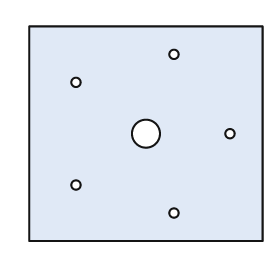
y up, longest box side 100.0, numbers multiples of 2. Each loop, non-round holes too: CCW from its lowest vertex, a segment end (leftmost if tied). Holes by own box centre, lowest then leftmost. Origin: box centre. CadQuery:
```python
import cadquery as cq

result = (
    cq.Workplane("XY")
    .moveTo(-50.0, -46.0)
    .lineTo(50.0, -46.0)
    .lineTo(50.0, 46.0)
    .lineTo(-50.0, 46.0)
    .close()
    .moveTo(12.0, -34.0)
    .circle(2.0)
    .moveTo(-30.0, -22.0)
    .circle(2.0)
    .moveTo(0.0, 0.0)
    .circle(6.0)
    .moveTo(36.0, 0.0)
    .circle(2.0)
    .moveTo(-30.0, 22.0)
    .circle(2.0)
    .moveTo(12.0, 34.0)
    .circle(2.0)
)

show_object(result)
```